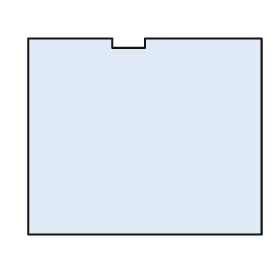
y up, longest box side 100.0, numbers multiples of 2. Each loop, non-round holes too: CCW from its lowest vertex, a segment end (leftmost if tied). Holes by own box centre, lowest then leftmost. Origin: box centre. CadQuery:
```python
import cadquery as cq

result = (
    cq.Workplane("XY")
    .moveTo(-50.0, -42.0)
    .lineTo(50.0, -42.0)
    .lineTo(50.0, 42.0)
    .lineTo(0.0, 42.0)
    .lineTo(0.0, 38.0)
    .lineTo(-14.0, 38.0)
    .lineTo(-14.0, 42.0)
    .lineTo(-50.0, 42.0)
    .close()
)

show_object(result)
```